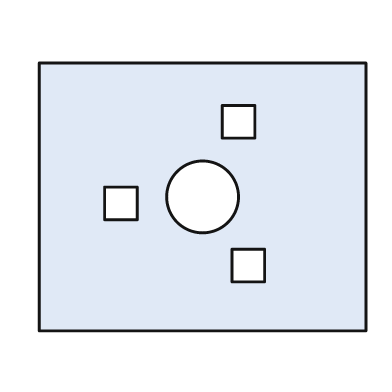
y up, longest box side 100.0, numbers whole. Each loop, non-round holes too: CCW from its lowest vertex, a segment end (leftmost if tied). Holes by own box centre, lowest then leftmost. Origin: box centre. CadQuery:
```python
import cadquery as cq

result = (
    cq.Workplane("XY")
    .moveTo(-50.0, -41.0)
    .lineTo(50.0, -41.0)
    .lineTo(50.0, 41.0)
    .lineTo(-50.0, 41.0)
    .close()
    .moveTo(9.0, -26.0)
    .lineTo(19.0, -26.0)
    .lineTo(19.0, -16.0)
    .lineTo(9.0, -16.0)
    .close()
    .moveTo(-30.0, -7.0)
    .lineTo(-20.0, -7.0)
    .lineTo(-20.0, 3.0)
    .lineTo(-30.0, 3.0)
    .close()
    .moveTo(0.0, 0.0)
    .circle(11.0)
    .moveTo(6.0, 18.0)
    .lineTo(16.0, 18.0)
    .lineTo(16.0, 28.0)
    .lineTo(6.0, 28.0)
    .close()
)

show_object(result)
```